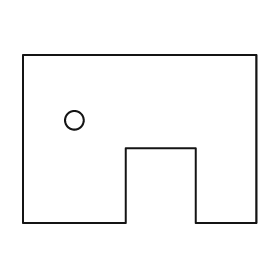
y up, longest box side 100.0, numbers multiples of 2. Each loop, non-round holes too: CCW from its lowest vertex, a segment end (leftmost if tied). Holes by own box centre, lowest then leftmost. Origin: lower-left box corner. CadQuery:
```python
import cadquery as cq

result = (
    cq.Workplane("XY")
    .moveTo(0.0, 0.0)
    .lineTo(44.0, 0.0)
    .lineTo(44.0, 32.0)
    .lineTo(74.0, 32.0)
    .lineTo(74.0, 0.0)
    .lineTo(100.0, 0.0)
    .lineTo(100.0, 72.0)
    .lineTo(0.0, 72.0)
    .close()
    .moveTo(22.0, 44.0)
    .circle(4.0)
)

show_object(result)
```